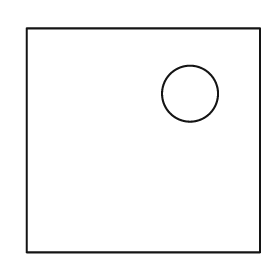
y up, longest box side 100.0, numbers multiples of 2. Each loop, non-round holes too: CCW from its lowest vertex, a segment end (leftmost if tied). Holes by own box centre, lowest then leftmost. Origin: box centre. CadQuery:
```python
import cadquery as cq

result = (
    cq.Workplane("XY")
    .moveTo(-50.0, -48.0)
    .lineTo(50.0, -48.0)
    .lineTo(50.0, 48.0)
    .lineTo(-50.0, 48.0)
    .close()
    .moveTo(20.0, 20.0)
    .circle(12.0)
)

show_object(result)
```